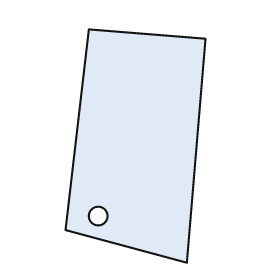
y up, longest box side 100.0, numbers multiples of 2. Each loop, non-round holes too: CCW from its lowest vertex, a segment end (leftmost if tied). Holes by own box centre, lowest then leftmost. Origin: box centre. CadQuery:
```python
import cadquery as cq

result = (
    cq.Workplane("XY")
    .moveTo(22.0, -50.0)
    .lineTo(30.0, 46.0)
    .lineTo(-20.0, 50.0)
    .lineTo(-30.0, -36.0)
    .close()
    .moveTo(-16.0, -30.0)
    .circle(4.0)
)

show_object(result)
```